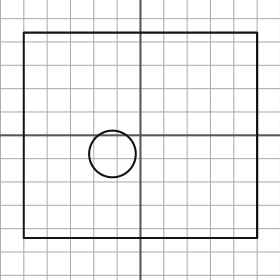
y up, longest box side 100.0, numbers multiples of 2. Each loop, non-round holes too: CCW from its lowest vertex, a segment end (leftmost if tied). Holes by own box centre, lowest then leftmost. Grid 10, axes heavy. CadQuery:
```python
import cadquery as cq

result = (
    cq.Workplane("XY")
    .moveTo(-50.0, -44.0)
    .lineTo(50.0, -44.0)
    .lineTo(50.0, 44.0)
    .lineTo(-50.0, 44.0)
    .close()
    .moveTo(-12.0, -8.0)
    .circle(10.0)
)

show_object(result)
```